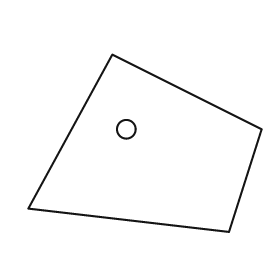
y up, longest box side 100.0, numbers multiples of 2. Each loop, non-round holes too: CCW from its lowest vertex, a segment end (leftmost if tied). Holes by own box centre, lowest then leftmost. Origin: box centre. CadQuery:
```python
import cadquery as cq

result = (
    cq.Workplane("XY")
    .moveTo(36.0, -38.0)
    .lineTo(50.0, 6.0)
    .lineTo(-14.0, 38.0)
    .lineTo(-50.0, -28.0)
    .close()
    .moveTo(-8.0, 6.0)
    .circle(4.0)
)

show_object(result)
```